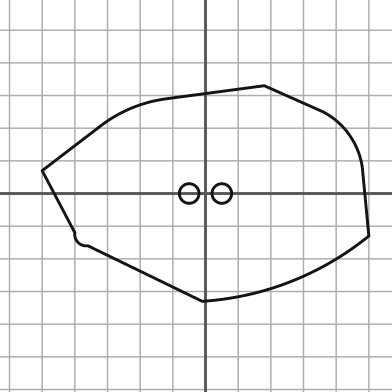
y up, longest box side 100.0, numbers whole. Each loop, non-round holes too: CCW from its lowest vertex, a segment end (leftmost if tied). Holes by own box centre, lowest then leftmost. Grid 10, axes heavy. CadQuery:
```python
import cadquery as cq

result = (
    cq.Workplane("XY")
    .moveTo(-1.0, -33.0)
    .threePointArc((26.0, -27.0), (50.0, -13.0))
    .lineTo(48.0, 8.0)
    .threePointArc((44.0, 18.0), (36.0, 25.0))
    .lineTo(18.0, 33.0)
    .lineTo(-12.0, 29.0)
    .threePointArc((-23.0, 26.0), (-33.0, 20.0))
    .lineTo(-50.0, 7.0)
    .lineTo(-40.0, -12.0)
    .threePointArc((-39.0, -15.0), (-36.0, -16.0))
    .close()
    .moveTo(-5.0, 0.0)
    .circle(3.0)
    .moveTo(5.0, 0.0)
    .circle(3.0)
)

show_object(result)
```